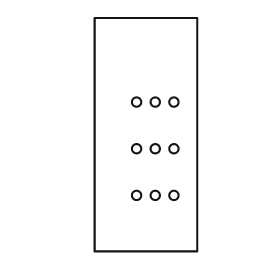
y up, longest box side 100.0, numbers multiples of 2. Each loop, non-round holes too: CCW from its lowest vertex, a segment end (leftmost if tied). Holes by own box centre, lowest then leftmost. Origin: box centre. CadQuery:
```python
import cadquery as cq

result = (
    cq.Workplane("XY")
    .moveTo(-22.0, -50.0)
    .lineTo(22.0, -50.0)
    .lineTo(22.0, 50.0)
    .lineTo(-22.0, 50.0)
    .close()
    .moveTo(-4.0, -26.0)
    .circle(2.0)
    .moveTo(4.0, -26.0)
    .circle(2.0)
    .moveTo(12.0, -26.0)
    .circle(2.0)
    .moveTo(-4.0, -6.0)
    .circle(2.0)
    .moveTo(4.0, -6.0)
    .circle(2.0)
    .moveTo(12.0, -6.0)
    .circle(2.0)
    .moveTo(-4.0, 14.0)
    .circle(2.0)
    .moveTo(4.0, 14.0)
    .circle(2.0)
    .moveTo(12.0, 14.0)
    .circle(2.0)
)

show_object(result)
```